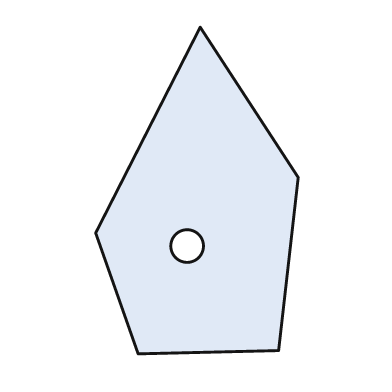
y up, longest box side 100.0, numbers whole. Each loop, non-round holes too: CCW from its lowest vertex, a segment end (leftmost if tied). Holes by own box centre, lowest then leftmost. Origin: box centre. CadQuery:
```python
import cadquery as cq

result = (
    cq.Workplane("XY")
    .moveTo(-18.0, -50.0)
    .lineTo(25.0, -49.0)
    .lineTo(31.0, 4.0)
    .lineTo(1.0, 50.0)
    .lineTo(-31.0, -13.0)
    .close()
    .moveTo(-3.0, -17.0)
    .circle(5.0)
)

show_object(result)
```